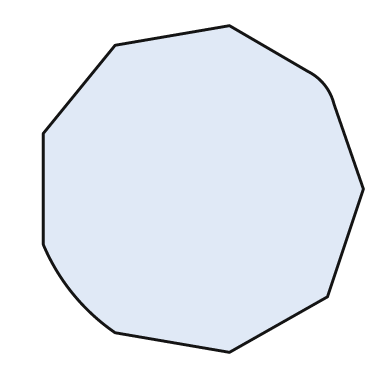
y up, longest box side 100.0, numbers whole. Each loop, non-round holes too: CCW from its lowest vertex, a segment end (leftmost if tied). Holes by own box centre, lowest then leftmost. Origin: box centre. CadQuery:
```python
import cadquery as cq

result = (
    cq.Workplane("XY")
    .moveTo(8.0, -50.0)
    .lineTo(38.0, -33.0)
    .lineTo(49.0, 0.0)
    .lineTo(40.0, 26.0)
    .threePointArc((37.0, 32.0), (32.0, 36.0))
    .lineTo(8.0, 50.0)
    .lineTo(-27.0, 44.0)
    .lineTo(-49.0, 17.0)
    .lineTo(-49.0, -17.0)
    .threePointArc((-40.0, -32.0), (-27.0, -44.0))
    .close()
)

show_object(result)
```